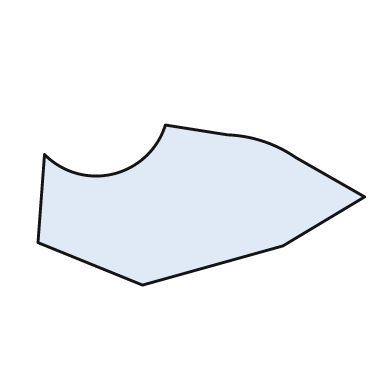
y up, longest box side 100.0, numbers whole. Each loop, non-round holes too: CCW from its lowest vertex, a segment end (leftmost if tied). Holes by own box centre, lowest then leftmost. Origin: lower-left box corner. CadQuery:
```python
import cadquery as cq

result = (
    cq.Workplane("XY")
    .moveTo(32.0, 0.0)
    .lineTo(75.0, 12.0)
    .lineTo(100.0, 27.0)
    .lineTo(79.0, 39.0)
    .threePointArc((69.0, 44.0), (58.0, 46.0))
    .lineTo(39.0, 49.0)
    .threePointArc((23.0, 34.0), (2.0, 40.0))
    .lineTo(0.0, 13.0)
    .close()
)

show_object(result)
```